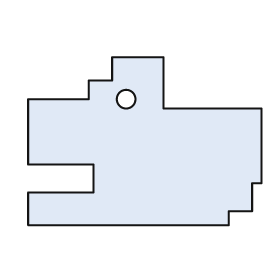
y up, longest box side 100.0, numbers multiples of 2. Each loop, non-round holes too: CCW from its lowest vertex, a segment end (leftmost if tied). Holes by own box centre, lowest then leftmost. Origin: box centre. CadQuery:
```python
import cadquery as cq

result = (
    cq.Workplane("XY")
    .moveTo(-50.0, -36.0)
    .lineTo(36.0, -36.0)
    .lineTo(36.0, -30.0)
    .lineTo(46.0, -30.0)
    .lineTo(46.0, -18.0)
    .lineTo(50.0, -18.0)
    .lineTo(50.0, 14.0)
    .lineTo(8.0, 14.0)
    .lineTo(8.0, 36.0)
    .lineTo(-14.0, 36.0)
    .lineTo(-14.0, 26.0)
    .lineTo(-24.0, 26.0)
    .lineTo(-24.0, 18.0)
    .lineTo(-50.0, 18.0)
    .lineTo(-50.0, -10.0)
    .lineTo(-22.0, -10.0)
    .lineTo(-22.0, -22.0)
    .lineTo(-50.0, -22.0)
    .close()
    .moveTo(-8.0, 18.0)
    .circle(4.0)
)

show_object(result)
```